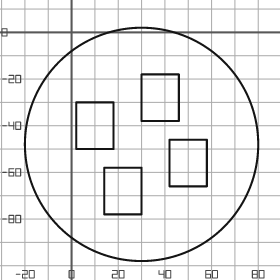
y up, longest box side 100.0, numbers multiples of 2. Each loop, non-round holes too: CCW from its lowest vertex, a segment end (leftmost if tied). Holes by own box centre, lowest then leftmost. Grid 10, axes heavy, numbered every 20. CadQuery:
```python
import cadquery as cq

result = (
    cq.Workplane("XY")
    .moveTo(30.0, -48.0)
    .circle(50.0)
    .moveTo(14.0, -78.0)
    .lineTo(30.0, -78.0)
    .lineTo(30.0, -58.0)
    .lineTo(14.0, -58.0)
    .close()
    .moveTo(42.0, -66.0)
    .lineTo(58.0, -66.0)
    .lineTo(58.0, -46.0)
    .lineTo(42.0, -46.0)
    .close()
    .moveTo(2.0, -50.0)
    .lineTo(18.0, -50.0)
    .lineTo(18.0, -30.0)
    .lineTo(2.0, -30.0)
    .close()
    .moveTo(30.0, -38.0)
    .lineTo(46.0, -38.0)
    .lineTo(46.0, -18.0)
    .lineTo(30.0, -18.0)
    .close()
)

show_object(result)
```